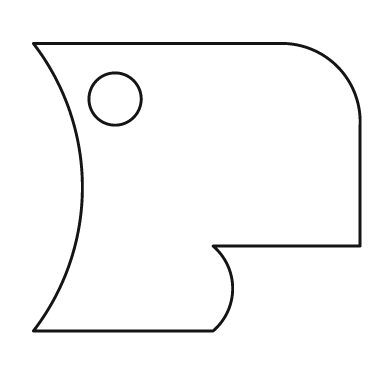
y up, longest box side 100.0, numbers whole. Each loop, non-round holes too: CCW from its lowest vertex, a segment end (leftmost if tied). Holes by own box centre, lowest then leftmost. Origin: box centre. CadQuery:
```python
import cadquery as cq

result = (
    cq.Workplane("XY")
    .moveTo(-50.0, -44.0)
    .lineTo(5.0, -44.0)
    .threePointArc((11.0, -31.0), (5.0, -18.0))
    .lineTo(50.0, -18.0)
    .lineTo(50.0, 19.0)
    .threePointArc((43.0, 37.0), (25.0, 44.0))
    .lineTo(-50.0, 44.0)
    .threePointArc((-35.0, 0.0), (-50.0, -44.0))
    .close()
    .moveTo(-25.0, 27.0)
    .circle(8.0)
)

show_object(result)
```